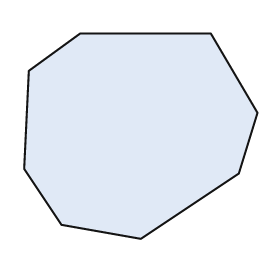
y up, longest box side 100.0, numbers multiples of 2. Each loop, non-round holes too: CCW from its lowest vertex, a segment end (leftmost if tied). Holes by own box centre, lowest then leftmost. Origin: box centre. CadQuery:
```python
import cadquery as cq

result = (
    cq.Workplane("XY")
    .moveTo(0.0, -44.0)
    .lineTo(42.0, -16.0)
    .lineTo(50.0, 10.0)
    .lineTo(30.0, 44.0)
    .lineTo(-26.0, 44.0)
    .lineTo(-48.0, 28.0)
    .lineTo(-50.0, -14.0)
    .lineTo(-34.0, -38.0)
    .close()
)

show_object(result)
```